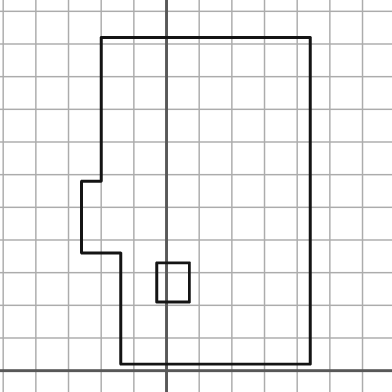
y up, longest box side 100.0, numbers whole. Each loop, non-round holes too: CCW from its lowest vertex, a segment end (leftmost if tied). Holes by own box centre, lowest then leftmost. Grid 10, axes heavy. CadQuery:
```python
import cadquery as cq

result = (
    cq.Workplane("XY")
    .moveTo(-14.0, 2.0)
    .lineTo(44.0, 2.0)
    .lineTo(44.0, 102.0)
    .lineTo(-20.0, 102.0)
    .lineTo(-20.0, 58.0)
    .lineTo(-26.0, 58.0)
    .lineTo(-26.0, 36.0)
    .lineTo(-14.0, 36.0)
    .close()
    .moveTo(-3.0, 21.0)
    .lineTo(7.0, 21.0)
    .lineTo(7.0, 33.0)
    .lineTo(-3.0, 33.0)
    .close()
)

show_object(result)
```